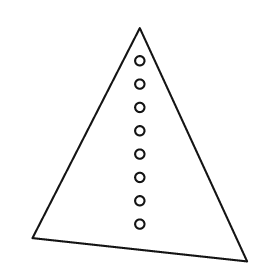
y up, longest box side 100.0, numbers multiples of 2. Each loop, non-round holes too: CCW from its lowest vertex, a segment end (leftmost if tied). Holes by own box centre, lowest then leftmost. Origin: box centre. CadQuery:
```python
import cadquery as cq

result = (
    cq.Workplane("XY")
    .moveTo(46.0, -50.0)
    .lineTo(0.0, 50.0)
    .lineTo(-46.0, -40.0)
    .close()
    .moveTo(0.0, -34.0)
    .circle(2.0)
    .moveTo(0.0, -24.0)
    .circle(2.0)
    .moveTo(0.0, -14.0)
    .circle(2.0)
    .moveTo(0.0, -4.0)
    .circle(2.0)
    .moveTo(0.0, 6.0)
    .circle(2.0)
    .moveTo(0.0, 16.0)
    .circle(2.0)
    .moveTo(0.0, 26.0)
    .circle(2.0)
    .moveTo(0.0, 36.0)
    .circle(2.0)
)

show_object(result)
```